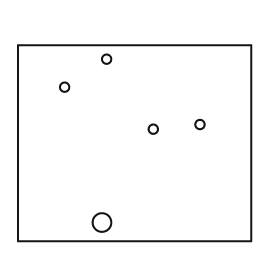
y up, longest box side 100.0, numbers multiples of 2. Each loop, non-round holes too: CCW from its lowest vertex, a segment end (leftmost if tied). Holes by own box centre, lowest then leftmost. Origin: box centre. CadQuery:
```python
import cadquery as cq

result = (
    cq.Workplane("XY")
    .moveTo(-50.0, -42.0)
    .lineTo(50.0, -42.0)
    .lineTo(50.0, 42.0)
    .lineTo(-50.0, 42.0)
    .close()
    .moveTo(-14.0, -34.0)
    .circle(4.0)
    .moveTo(8.0, 6.0)
    .circle(2.0)
    .moveTo(28.0, 8.0)
    .circle(2.0)
    .moveTo(-30.0, 24.0)
    .circle(2.0)
    .moveTo(-12.0, 36.0)
    .circle(2.0)
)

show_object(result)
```